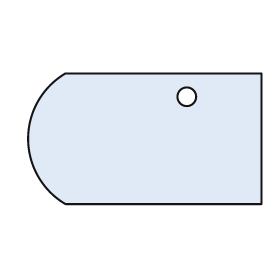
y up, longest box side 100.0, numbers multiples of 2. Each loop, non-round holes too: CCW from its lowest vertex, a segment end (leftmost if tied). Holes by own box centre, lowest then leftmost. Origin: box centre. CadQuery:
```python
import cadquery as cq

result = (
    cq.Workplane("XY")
    .moveTo(-34.0, -28.0)
    .lineTo(50.0, -28.0)
    .lineTo(50.0, 28.0)
    .lineTo(-34.0, 28.0)
    .threePointArc((-50.0, 0.0), (-34.0, -28.0))
    .close()
    .moveTo(18.0, 18.0)
    .circle(4.0)
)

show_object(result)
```